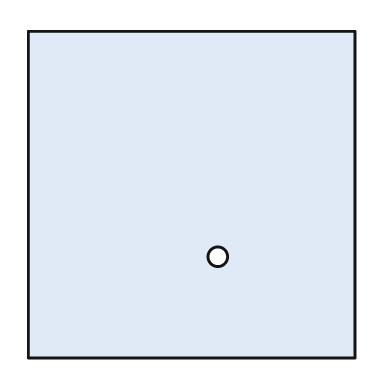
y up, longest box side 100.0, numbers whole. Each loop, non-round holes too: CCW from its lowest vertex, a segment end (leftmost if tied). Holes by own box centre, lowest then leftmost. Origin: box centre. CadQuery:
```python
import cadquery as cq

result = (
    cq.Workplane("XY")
    .moveTo(-50.0, -50.0)
    .lineTo(50.0, -50.0)
    .lineTo(50.0, 50.0)
    .lineTo(-50.0, 50.0)
    .close()
    .moveTo(8.0, -19.0)
    .circle(3.0)
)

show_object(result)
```